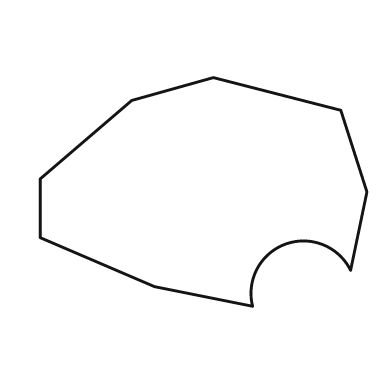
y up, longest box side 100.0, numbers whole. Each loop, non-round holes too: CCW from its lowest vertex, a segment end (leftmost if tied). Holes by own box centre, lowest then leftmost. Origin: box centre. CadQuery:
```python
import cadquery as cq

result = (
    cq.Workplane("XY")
    .moveTo(15.0, -35.0)
    .threePointArc((25.0, -16.0), (45.0, -24.0))
    .lineTo(50.0, 0.0)
    .lineTo(42.0, 25.0)
    .lineTo(3.0, 35.0)
    .lineTo(-22.0, 28.0)
    .lineTo(-50.0, 4.0)
    .lineTo(-50.0, -14.0)
    .lineTo(-15.0, -29.0)
    .close()
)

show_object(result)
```